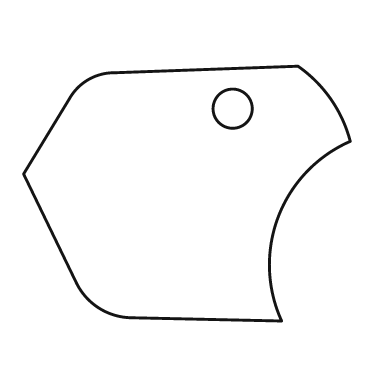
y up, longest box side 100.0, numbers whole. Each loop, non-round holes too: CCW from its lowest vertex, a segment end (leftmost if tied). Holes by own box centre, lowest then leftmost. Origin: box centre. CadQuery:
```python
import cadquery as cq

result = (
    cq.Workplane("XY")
    .moveTo(29.0, -39.0)
    .threePointArc((28.0, -7.0), (50.0, 16.0))
    .threePointArc((44.0, 29.0), (34.0, 39.0))
    .lineTo(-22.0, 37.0)
    .threePointArc((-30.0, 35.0), (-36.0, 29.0))
    .lineTo(-50.0, 6.0)
    .lineTo(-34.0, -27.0)
    .threePointArc((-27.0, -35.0), (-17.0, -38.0))
    .close()
    .moveTo(14.0, 26.0)
    .circle(6.0)
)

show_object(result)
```